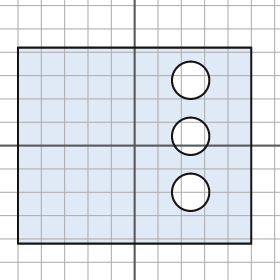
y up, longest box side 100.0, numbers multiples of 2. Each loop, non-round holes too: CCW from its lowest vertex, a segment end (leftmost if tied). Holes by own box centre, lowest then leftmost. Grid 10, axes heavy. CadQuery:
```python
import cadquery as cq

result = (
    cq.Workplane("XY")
    .moveTo(-50.0, -42.0)
    .lineTo(50.0, -42.0)
    .lineTo(50.0, 42.0)
    .lineTo(-50.0, 42.0)
    .close()
    .moveTo(24.0, -20.0)
    .circle(8.0)
    .moveTo(24.0, 4.0)
    .circle(8.0)
    .moveTo(24.0, 28.0)
    .circle(8.0)
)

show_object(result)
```